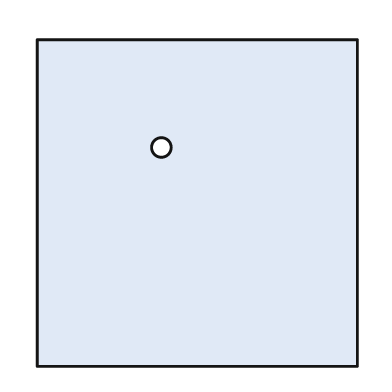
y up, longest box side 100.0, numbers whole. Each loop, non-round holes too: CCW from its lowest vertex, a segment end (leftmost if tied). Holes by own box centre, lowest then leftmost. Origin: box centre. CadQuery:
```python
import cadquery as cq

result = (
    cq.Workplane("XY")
    .moveTo(-49.0, -50.0)
    .lineTo(49.0, -50.0)
    .lineTo(49.0, 50.0)
    .lineTo(-49.0, 50.0)
    .close()
    .moveTo(-11.0, 17.0)
    .circle(3.0)
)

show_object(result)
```